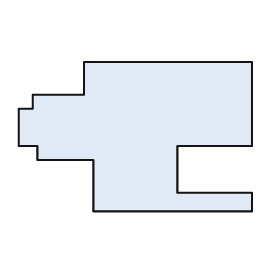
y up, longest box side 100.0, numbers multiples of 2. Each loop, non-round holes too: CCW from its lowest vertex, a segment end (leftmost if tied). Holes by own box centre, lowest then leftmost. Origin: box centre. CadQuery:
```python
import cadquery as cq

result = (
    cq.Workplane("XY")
    .moveTo(-18.0, -32.0)
    .lineTo(50.0, -32.0)
    .lineTo(50.0, -24.0)
    .lineTo(18.0, -24.0)
    .lineTo(18.0, -4.0)
    .lineTo(50.0, -4.0)
    .lineTo(50.0, 32.0)
    .lineTo(-22.0, 32.0)
    .lineTo(-22.0, 18.0)
    .lineTo(-44.0, 18.0)
    .lineTo(-44.0, 12.0)
    .lineTo(-50.0, 12.0)
    .lineTo(-50.0, -4.0)
    .lineTo(-42.0, -4.0)
    .lineTo(-42.0, -10.0)
    .lineTo(-18.0, -10.0)
    .close()
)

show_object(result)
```